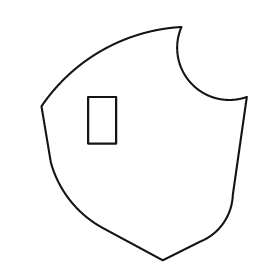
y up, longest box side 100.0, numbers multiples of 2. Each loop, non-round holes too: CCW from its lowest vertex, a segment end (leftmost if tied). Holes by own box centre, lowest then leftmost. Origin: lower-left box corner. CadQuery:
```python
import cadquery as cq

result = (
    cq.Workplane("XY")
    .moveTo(52.0, 0.0)
    .lineTo(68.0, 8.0)
    .threePointArc((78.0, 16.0), (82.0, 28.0))
    .lineTo(88.0, 70.0)
    .threePointArc((64.0, 76.0), (60.0, 100.0))
    .threePointArc((26.0, 90.0), (0.0, 66.0))
    .lineTo(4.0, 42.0)
    .threePointArc((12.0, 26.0), (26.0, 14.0))
    .close()
    .moveTo(20.0, 50.0)
    .lineTo(32.0, 50.0)
    .lineTo(32.0, 70.0)
    .lineTo(20.0, 70.0)
    .close()
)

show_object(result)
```